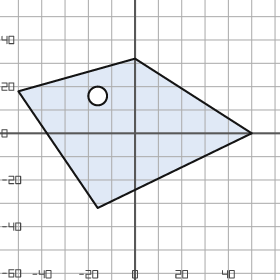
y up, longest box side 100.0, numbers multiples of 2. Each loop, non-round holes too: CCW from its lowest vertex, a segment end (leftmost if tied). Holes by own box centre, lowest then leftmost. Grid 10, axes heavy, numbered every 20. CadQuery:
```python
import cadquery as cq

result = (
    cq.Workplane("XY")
    .moveTo(-16.0, -32.0)
    .lineTo(50.0, 0.0)
    .lineTo(0.0, 32.0)
    .lineTo(-50.0, 18.0)
    .close()
    .moveTo(-16.0, 16.0)
    .circle(4.0)
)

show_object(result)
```